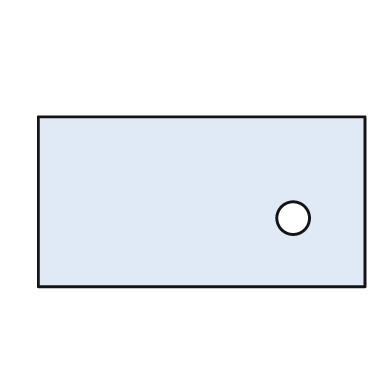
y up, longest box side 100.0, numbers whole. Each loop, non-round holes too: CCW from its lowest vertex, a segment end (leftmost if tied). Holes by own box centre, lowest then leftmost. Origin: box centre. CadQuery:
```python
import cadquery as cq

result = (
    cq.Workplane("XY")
    .moveTo(-50.0, -26.0)
    .lineTo(50.0, -26.0)
    .lineTo(50.0, 26.0)
    .lineTo(-50.0, 26.0)
    .close()
    .moveTo(28.0, -5.0)
    .circle(5.0)
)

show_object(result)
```